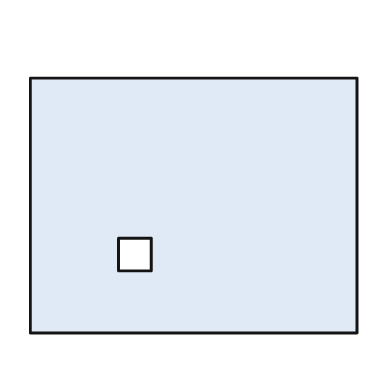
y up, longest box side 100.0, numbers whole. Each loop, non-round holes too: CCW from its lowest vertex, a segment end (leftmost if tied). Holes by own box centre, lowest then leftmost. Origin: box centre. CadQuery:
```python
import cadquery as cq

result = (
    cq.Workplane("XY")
    .moveTo(-50.0, -39.0)
    .lineTo(50.0, -39.0)
    .lineTo(50.0, 39.0)
    .lineTo(-50.0, 39.0)
    .close()
    .moveTo(-23.0, -20.0)
    .lineTo(-13.0, -20.0)
    .lineTo(-13.0, -10.0)
    .lineTo(-23.0, -10.0)
    .close()
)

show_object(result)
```